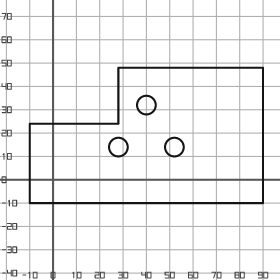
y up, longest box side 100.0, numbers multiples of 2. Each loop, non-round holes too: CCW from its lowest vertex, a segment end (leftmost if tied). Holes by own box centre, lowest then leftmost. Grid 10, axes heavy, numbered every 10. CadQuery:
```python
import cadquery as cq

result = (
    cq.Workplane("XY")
    .moveTo(-10.0, -10.0)
    .lineTo(90.0, -10.0)
    .lineTo(90.0, 48.0)
    .lineTo(28.0, 48.0)
    .lineTo(28.0, 24.0)
    .lineTo(-10.0, 24.0)
    .close()
    .moveTo(28.0, 14.0)
    .circle(4.0)
    .moveTo(52.0, 14.0)
    .circle(4.0)
    .moveTo(40.0, 32.0)
    .circle(4.0)
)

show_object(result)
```